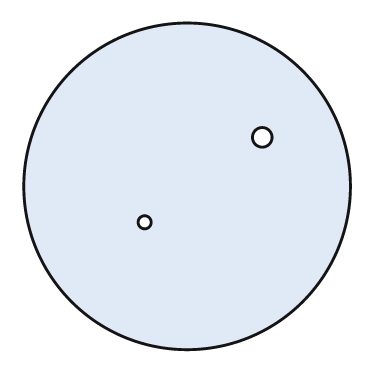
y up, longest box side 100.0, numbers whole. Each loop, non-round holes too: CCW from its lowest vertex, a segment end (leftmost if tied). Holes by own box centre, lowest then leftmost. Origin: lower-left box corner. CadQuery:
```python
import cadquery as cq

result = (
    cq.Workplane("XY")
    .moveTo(50.0, 50.0)
    .circle(50.0)
    .moveTo(37.0, 39.0)
    .circle(2.0)
    .moveTo(73.0, 65.0)
    .circle(3.0)
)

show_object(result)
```